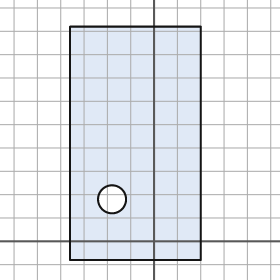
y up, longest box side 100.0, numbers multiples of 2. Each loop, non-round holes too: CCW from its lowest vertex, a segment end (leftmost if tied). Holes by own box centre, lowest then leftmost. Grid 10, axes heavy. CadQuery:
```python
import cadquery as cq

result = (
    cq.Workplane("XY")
    .moveTo(-36.0, -8.0)
    .lineTo(20.0, -8.0)
    .lineTo(20.0, 92.0)
    .lineTo(-36.0, 92.0)
    .close()
    .moveTo(-18.0, 18.0)
    .circle(6.0)
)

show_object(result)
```